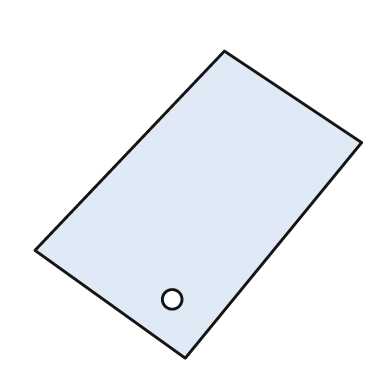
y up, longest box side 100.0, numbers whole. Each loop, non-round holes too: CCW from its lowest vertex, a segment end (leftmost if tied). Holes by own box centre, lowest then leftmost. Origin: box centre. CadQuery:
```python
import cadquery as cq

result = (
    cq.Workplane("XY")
    .moveTo(-4.0, -47.0)
    .lineTo(50.0, 19.0)
    .lineTo(8.0, 47.0)
    .lineTo(-50.0, -14.0)
    .close()
    .moveTo(-8.0, -29.0)
    .circle(3.0)
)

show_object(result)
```